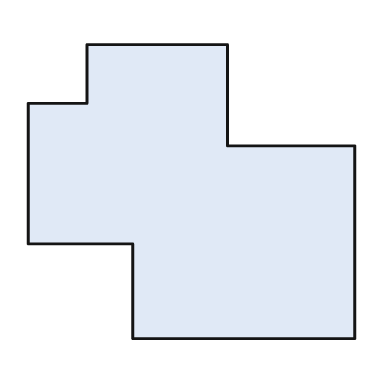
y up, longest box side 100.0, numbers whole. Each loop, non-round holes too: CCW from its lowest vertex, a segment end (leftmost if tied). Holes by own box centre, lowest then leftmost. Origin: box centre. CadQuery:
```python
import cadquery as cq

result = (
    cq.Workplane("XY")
    .moveTo(-18.0, -45.0)
    .lineTo(50.0, -45.0)
    .lineTo(50.0, 14.0)
    .lineTo(11.0, 14.0)
    .lineTo(11.0, 45.0)
    .lineTo(-32.0, 45.0)
    .lineTo(-32.0, 27.0)
    .lineTo(-50.0, 27.0)
    .lineTo(-50.0, -16.0)
    .lineTo(-18.0, -16.0)
    .close()
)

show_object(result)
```